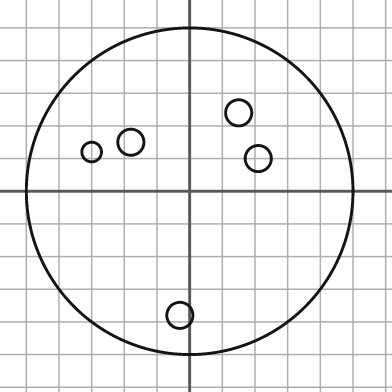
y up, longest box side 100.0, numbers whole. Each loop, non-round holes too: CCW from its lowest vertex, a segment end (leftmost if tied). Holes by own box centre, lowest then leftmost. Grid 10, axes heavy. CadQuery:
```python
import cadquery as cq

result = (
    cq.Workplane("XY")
    .moveTo(0.0, 0.0)
    .circle(50.0)
    .moveTo(-3.0, -38.0)
    .circle(4.0)
    .moveTo(21.0, 10.0)
    .circle(4.0)
    .moveTo(-30.0, 12.0)
    .circle(3.0)
    .moveTo(-18.0, 15.0)
    .circle(4.0)
    .moveTo(15.0, 24.0)
    .circle(4.0)
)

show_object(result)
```